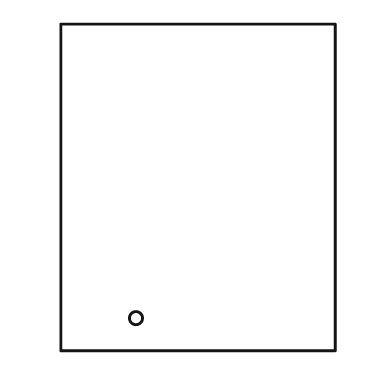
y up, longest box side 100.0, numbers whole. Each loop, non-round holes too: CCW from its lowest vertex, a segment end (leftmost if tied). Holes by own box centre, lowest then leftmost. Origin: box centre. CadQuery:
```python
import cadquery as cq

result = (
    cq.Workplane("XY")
    .moveTo(-42.0, -50.0)
    .lineTo(42.0, -50.0)
    .lineTo(42.0, 50.0)
    .lineTo(-42.0, 50.0)
    .close()
    .moveTo(-19.0, -40.0)
    .circle(2.0)
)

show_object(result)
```